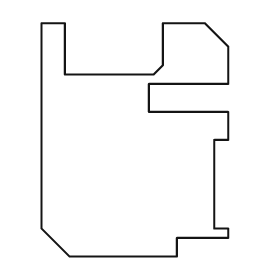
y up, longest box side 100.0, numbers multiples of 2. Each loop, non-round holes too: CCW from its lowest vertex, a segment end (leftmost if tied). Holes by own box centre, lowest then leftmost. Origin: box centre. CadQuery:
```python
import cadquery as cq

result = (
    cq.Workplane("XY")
    .moveTo(-28.0, -50.0)
    .lineTo(18.0, -50.0)
    .lineTo(18.0, -42.0)
    .lineTo(40.0, -42.0)
    .lineTo(40.0, -38.0)
    .lineTo(34.0, -38.0)
    .lineTo(34.0, 0.0)
    .lineTo(40.0, 0.0)
    .lineTo(40.0, 12.0)
    .lineTo(6.0, 12.0)
    .lineTo(6.0, 24.0)
    .lineTo(40.0, 24.0)
    .lineTo(40.0, 40.0)
    .lineTo(30.0, 50.0)
    .lineTo(12.0, 50.0)
    .lineTo(12.0, 32.0)
    .lineTo(8.0, 28.0)
    .lineTo(-30.0, 28.0)
    .lineTo(-30.0, 50.0)
    .lineTo(-40.0, 50.0)
    .lineTo(-40.0, -38.0)
    .close()
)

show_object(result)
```